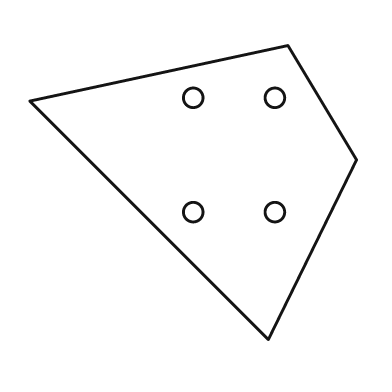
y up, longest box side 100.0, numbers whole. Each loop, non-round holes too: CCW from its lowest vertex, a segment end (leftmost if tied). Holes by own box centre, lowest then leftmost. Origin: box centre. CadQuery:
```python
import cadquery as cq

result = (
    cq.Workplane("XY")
    .moveTo(23.0, -45.0)
    .lineTo(50.0, 10.0)
    .lineTo(29.0, 45.0)
    .lineTo(-50.0, 28.0)
    .close()
    .moveTo(0.0, -6.0)
    .circle(3.0)
    .moveTo(25.0, -6.0)
    .circle(3.0)
    .moveTo(0.0, 29.0)
    .circle(3.0)
    .moveTo(25.0, 29.0)
    .circle(3.0)
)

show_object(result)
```